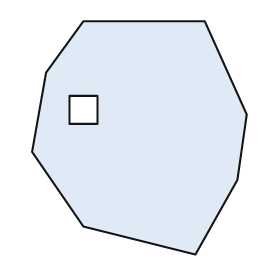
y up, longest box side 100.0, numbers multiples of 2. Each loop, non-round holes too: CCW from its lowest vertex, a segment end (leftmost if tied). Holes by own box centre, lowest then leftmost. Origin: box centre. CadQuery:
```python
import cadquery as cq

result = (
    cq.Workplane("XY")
    .moveTo(24.0, -50.0)
    .lineTo(42.0, -18.0)
    .lineTo(46.0, 10.0)
    .lineTo(28.0, 50.0)
    .lineTo(-24.0, 50.0)
    .lineTo(-40.0, 28.0)
    .lineTo(-46.0, -6.0)
    .lineTo(-24.0, -38.0)
    .close()
    .moveTo(-30.0, 6.0)
    .lineTo(-18.0, 6.0)
    .lineTo(-18.0, 18.0)
    .lineTo(-30.0, 18.0)
    .close()
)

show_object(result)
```